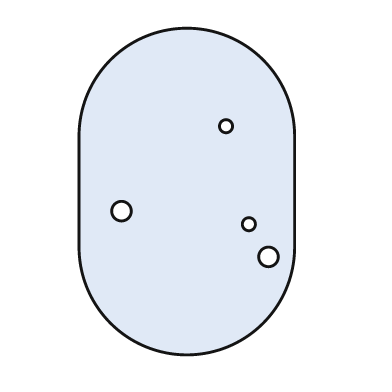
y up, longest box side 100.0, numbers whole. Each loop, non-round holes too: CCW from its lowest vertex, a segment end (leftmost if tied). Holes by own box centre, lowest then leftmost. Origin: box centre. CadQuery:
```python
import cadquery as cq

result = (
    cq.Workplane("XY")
    .moveTo(-33.0, -17.0)
    .threePointArc((0.0, -50.0), (33.0, -17.0))
    .lineTo(33.0, 17.0)
    .threePointArc((0.0, 50.0), (-33.0, 17.0))
    .close()
    .moveTo(25.0, -20.0)
    .circle(3.0)
    .moveTo(19.0, -10.0)
    .circle(2.0)
    .moveTo(-20.0, -6.0)
    .circle(3.0)
    .moveTo(12.0, 20.0)
    .circle(2.0)
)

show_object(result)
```